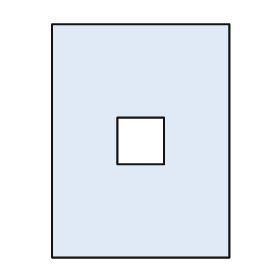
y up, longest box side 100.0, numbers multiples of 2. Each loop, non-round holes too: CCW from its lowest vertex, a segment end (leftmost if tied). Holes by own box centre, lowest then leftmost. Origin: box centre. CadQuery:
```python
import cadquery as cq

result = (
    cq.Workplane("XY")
    .moveTo(-38.0, -50.0)
    .lineTo(38.0, -50.0)
    .lineTo(38.0, 50.0)
    .lineTo(-38.0, 50.0)
    .close()
    .moveTo(-10.0, -10.0)
    .lineTo(10.0, -10.0)
    .lineTo(10.0, 10.0)
    .lineTo(-10.0, 10.0)
    .close()
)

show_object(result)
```